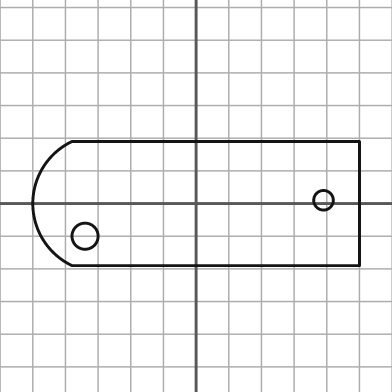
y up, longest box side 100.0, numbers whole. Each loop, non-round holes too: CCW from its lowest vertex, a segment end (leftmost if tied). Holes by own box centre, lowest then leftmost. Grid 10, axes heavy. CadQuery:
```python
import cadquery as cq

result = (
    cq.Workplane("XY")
    .moveTo(-38.0, -19.0)
    .lineTo(50.0, -19.0)
    .lineTo(50.0, 19.0)
    .lineTo(-38.0, 19.0)
    .threePointArc((-50.0, 0.0), (-38.0, -19.0))
    .close()
    .moveTo(-34.0, -10.0)
    .circle(4.0)
    .moveTo(39.0, 1.0)
    .circle(3.0)
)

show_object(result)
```